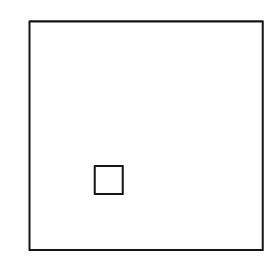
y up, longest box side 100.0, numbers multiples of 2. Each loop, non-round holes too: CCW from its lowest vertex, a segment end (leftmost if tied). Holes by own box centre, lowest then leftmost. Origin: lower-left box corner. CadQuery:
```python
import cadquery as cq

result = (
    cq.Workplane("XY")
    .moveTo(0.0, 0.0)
    .lineTo(100.0, 0.0)
    .lineTo(100.0, 98.0)
    .lineTo(0.0, 98.0)
    .close()
    .moveTo(28.0, 24.0)
    .lineTo(40.0, 24.0)
    .lineTo(40.0, 36.0)
    .lineTo(28.0, 36.0)
    .close()
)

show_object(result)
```